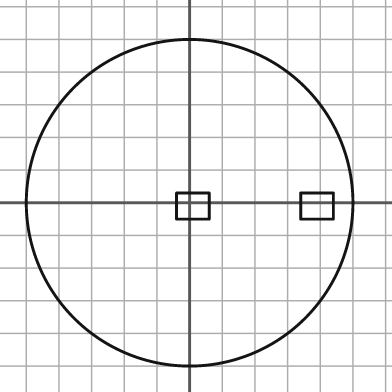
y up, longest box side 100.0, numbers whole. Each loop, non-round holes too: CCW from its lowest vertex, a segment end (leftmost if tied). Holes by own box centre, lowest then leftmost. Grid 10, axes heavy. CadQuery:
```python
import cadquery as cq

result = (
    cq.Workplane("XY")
    .moveTo(0.0, 0.0)
    .circle(50.0)
    .moveTo(-4.0, -5.0)
    .lineTo(6.0, -5.0)
    .lineTo(6.0, 3.0)
    .lineTo(-4.0, 3.0)
    .close()
    .moveTo(34.0, -5.0)
    .lineTo(44.0, -5.0)
    .lineTo(44.0, 3.0)
    .lineTo(34.0, 3.0)
    .close()
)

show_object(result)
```